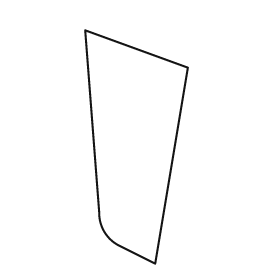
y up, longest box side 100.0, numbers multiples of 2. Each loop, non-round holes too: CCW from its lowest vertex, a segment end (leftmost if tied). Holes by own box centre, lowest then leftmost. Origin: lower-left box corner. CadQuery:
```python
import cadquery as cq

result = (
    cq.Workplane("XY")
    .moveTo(30.0, 0.0)
    .lineTo(44.0, 84.0)
    .lineTo(0.0, 100.0)
    .lineTo(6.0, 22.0)
    .threePointArc((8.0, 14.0), (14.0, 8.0))
    .close()
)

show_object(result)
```